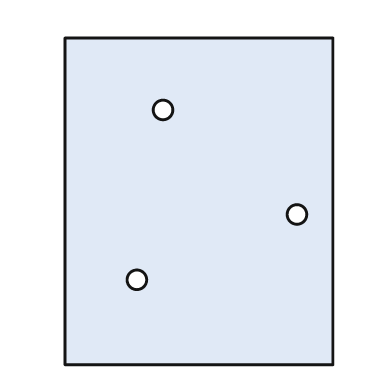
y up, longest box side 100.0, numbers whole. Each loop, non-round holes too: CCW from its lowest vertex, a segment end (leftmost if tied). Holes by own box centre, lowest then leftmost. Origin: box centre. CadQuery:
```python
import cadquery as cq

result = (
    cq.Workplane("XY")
    .moveTo(-41.0, -50.0)
    .lineTo(41.0, -50.0)
    .lineTo(41.0, 50.0)
    .lineTo(-41.0, 50.0)
    .close()
    .moveTo(-19.0, -24.0)
    .circle(3.0)
    .moveTo(30.0, -4.0)
    .circle(3.0)
    .moveTo(-11.0, 28.0)
    .circle(3.0)
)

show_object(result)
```